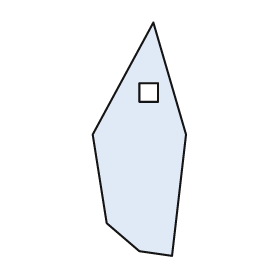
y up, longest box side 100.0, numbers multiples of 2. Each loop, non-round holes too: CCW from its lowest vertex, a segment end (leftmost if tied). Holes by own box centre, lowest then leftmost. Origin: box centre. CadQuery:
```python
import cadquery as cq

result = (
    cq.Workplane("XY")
    .moveTo(14.0, -50.0)
    .lineTo(20.0, 2.0)
    .lineTo(6.0, 50.0)
    .lineTo(-20.0, 2.0)
    .lineTo(-14.0, -36.0)
    .lineTo(0.0, -48.0)
    .close()
    .moveTo(0.0, 16.0)
    .lineTo(8.0, 16.0)
    .lineTo(8.0, 24.0)
    .lineTo(0.0, 24.0)
    .close()
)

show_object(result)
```